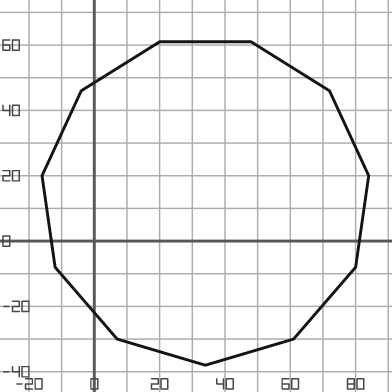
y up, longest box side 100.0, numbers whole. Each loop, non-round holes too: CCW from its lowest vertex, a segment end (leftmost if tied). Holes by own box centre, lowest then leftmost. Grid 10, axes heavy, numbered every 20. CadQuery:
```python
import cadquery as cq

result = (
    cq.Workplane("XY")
    .moveTo(34.0, -38.0)
    .lineTo(61.0, -30.0)
    .lineTo(80.0, -8.0)
    .lineTo(84.0, 20.0)
    .lineTo(72.0, 46.0)
    .lineTo(48.0, 61.0)
    .lineTo(20.0, 61.0)
    .lineTo(-4.0, 46.0)
    .lineTo(-16.0, 20.0)
    .lineTo(-12.0, -8.0)
    .lineTo(7.0, -30.0)
    .close()
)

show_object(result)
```